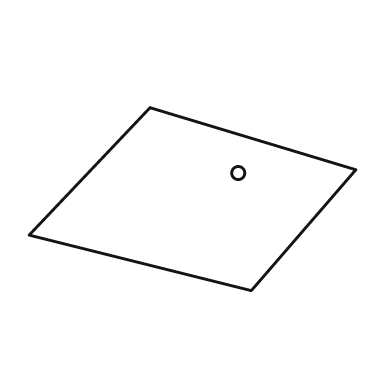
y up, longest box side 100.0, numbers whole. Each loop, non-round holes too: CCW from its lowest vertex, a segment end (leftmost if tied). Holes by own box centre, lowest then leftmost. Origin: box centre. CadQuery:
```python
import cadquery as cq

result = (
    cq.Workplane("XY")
    .moveTo(18.0, -28.0)
    .lineTo(50.0, 9.0)
    .lineTo(-13.0, 28.0)
    .lineTo(-50.0, -11.0)
    .close()
    .moveTo(14.0, 8.0)
    .circle(2.0)
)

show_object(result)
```